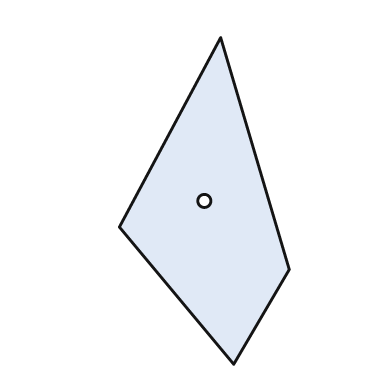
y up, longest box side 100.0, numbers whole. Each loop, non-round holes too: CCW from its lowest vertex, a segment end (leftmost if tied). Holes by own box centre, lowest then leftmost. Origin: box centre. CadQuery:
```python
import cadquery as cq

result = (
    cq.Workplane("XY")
    .moveTo(9.0, -50.0)
    .lineTo(26.0, -21.0)
    .lineTo(5.0, 50.0)
    .lineTo(-26.0, -8.0)
    .close()
    .moveTo(0.0, 0.0)
    .circle(2.0)
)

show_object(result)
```